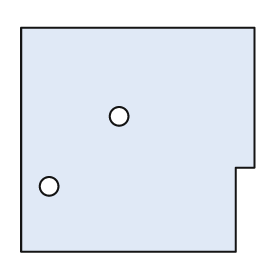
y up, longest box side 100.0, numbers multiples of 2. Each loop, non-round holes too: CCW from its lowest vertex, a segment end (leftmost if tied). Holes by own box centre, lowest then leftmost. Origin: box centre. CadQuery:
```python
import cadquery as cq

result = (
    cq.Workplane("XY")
    .moveTo(-50.0, -48.0)
    .lineTo(42.0, -48.0)
    .lineTo(42.0, -12.0)
    .lineTo(50.0, -12.0)
    .lineTo(50.0, 48.0)
    .lineTo(-50.0, 48.0)
    .close()
    .moveTo(-38.0, -20.0)
    .circle(4.0)
    .moveTo(-8.0, 10.0)
    .circle(4.0)
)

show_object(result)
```